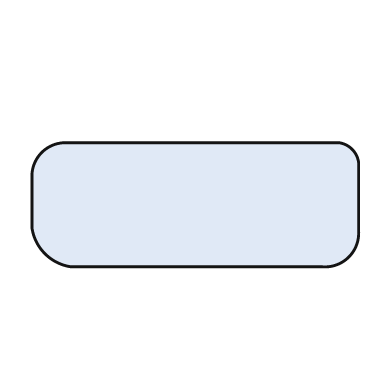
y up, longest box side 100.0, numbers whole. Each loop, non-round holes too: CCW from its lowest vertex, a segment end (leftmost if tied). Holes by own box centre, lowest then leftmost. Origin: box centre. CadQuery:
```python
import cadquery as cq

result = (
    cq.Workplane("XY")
    .moveTo(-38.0, -19.0)
    .lineTo(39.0, -19.0)
    .threePointArc((47.0, -16.0), (50.0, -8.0))
    .lineTo(50.0, 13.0)
    .threePointArc((48.0, 17.0), (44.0, 19.0))
    .lineTo(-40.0, 19.0)
    .threePointArc((-47.0, 16.0), (-50.0, 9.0))
    .lineTo(-50.0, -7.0)
    .threePointArc((-46.0, -15.0), (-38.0, -19.0))
    .close()
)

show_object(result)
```